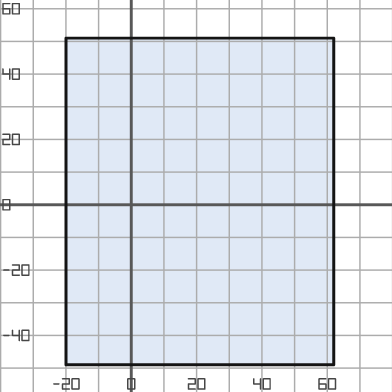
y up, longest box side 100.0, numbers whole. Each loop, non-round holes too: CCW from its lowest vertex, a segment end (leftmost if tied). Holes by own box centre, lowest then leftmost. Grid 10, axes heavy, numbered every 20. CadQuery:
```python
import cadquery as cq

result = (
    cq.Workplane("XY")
    .moveTo(-20.0, -49.0)
    .lineTo(62.0, -49.0)
    .lineTo(62.0, 51.0)
    .lineTo(-20.0, 51.0)
    .close()
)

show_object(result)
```